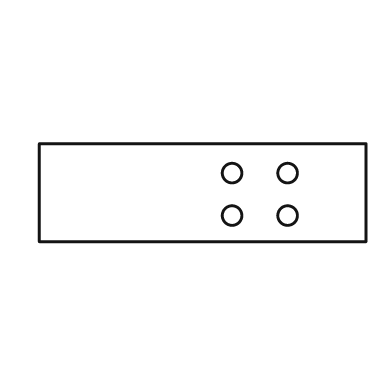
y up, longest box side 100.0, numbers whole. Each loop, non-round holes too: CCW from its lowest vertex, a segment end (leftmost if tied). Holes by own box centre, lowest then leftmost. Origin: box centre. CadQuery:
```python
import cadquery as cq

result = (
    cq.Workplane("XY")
    .moveTo(-50.0, -15.0)
    .lineTo(50.0, -15.0)
    .lineTo(50.0, 15.0)
    .lineTo(-50.0, 15.0)
    .close()
    .moveTo(9.0, -7.0)
    .circle(3.0)
    .moveTo(26.0, -7.0)
    .circle(3.0)
    .moveTo(9.0, 6.0)
    .circle(3.0)
    .moveTo(26.0, 6.0)
    .circle(3.0)
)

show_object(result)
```